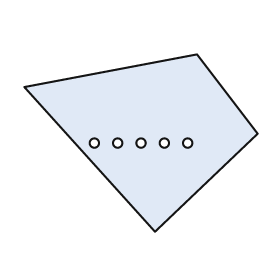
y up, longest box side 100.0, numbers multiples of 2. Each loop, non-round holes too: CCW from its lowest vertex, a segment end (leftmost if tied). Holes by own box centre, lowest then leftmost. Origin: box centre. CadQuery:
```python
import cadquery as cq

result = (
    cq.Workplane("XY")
    .moveTo(6.0, -38.0)
    .lineTo(50.0, 4.0)
    .lineTo(24.0, 38.0)
    .lineTo(-50.0, 24.0)
    .close()
    .moveTo(-20.0, 0.0)
    .circle(2.0)
    .moveTo(-10.0, 0.0)
    .circle(2.0)
    .moveTo(0.0, 0.0)
    .circle(2.0)
    .moveTo(10.0, 0.0)
    .circle(2.0)
    .moveTo(20.0, 0.0)
    .circle(2.0)
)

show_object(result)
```